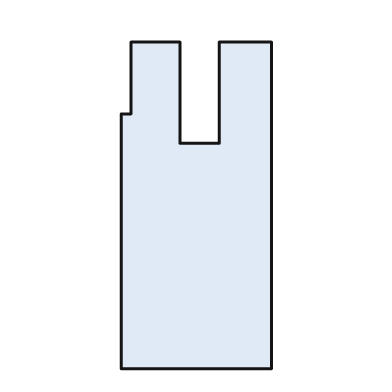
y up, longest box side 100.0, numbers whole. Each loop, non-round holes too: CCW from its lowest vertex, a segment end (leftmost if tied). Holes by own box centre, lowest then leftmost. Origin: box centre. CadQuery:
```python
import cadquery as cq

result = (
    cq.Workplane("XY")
    .moveTo(-23.0, -50.0)
    .lineTo(23.0, -50.0)
    .lineTo(23.0, 50.0)
    .lineTo(7.0, 50.0)
    .lineTo(7.0, 19.0)
    .lineTo(-5.0, 19.0)
    .lineTo(-5.0, 50.0)
    .lineTo(-20.0, 50.0)
    .lineTo(-20.0, 28.0)
    .lineTo(-23.0, 28.0)
    .close()
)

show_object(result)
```